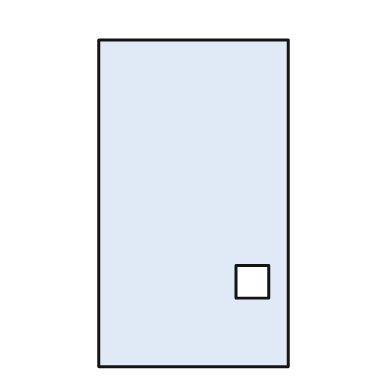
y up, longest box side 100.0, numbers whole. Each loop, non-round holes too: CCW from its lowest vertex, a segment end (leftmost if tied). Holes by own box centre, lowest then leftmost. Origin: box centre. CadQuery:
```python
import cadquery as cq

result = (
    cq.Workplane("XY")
    .moveTo(-29.0, -50.0)
    .lineTo(29.0, -50.0)
    .lineTo(29.0, 50.0)
    .lineTo(-29.0, 50.0)
    .close()
    .moveTo(13.0, -29.0)
    .lineTo(23.0, -29.0)
    .lineTo(23.0, -19.0)
    .lineTo(13.0, -19.0)
    .close()
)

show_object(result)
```